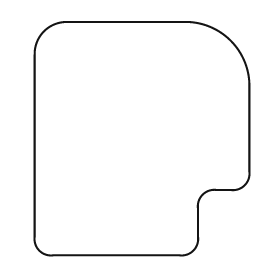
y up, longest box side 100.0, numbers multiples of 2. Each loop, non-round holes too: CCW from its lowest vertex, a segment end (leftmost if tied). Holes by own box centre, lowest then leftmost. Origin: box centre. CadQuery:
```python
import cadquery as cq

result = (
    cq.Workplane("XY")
    .moveTo(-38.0, -50.0)
    .lineTo(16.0, -50.0)
    .threePointArc((22.0, -48.0), (24.0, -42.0))
    .lineTo(24.0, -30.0)
    .threePointArc((26.0, -24.0), (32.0, -22.0))
    .lineTo(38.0, -22.0)
    .threePointArc((44.0, -20.0), (46.0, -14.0))
    .lineTo(46.0, 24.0)
    .threePointArc((38.0, 42.0), (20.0, 50.0))
    .lineTo(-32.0, 50.0)
    .threePointArc((-42.0, 46.0), (-46.0, 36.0))
    .lineTo(-46.0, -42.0)
    .threePointArc((-44.0, -48.0), (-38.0, -50.0))
    .close()
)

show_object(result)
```